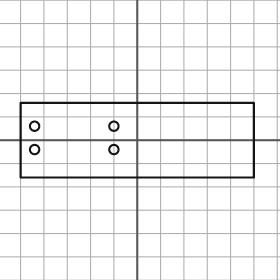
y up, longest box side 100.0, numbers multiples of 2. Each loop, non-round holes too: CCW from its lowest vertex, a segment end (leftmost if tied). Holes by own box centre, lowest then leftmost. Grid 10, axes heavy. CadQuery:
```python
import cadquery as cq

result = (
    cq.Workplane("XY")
    .moveTo(-50.0, -16.0)
    .lineTo(50.0, -16.0)
    .lineTo(50.0, 16.0)
    .lineTo(-50.0, 16.0)
    .close()
    .moveTo(-44.0, -4.0)
    .circle(2.0)
    .moveTo(-10.0, -4.0)
    .circle(2.0)
    .moveTo(-44.0, 6.0)
    .circle(2.0)
    .moveTo(-10.0, 6.0)
    .circle(2.0)
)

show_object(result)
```